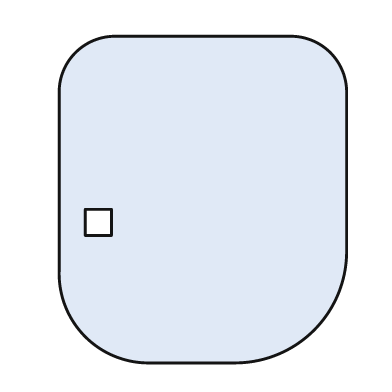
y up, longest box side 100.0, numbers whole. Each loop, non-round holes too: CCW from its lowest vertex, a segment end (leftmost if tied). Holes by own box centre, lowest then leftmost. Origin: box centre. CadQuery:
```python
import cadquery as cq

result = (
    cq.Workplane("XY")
    .moveTo(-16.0, -50.0)
    .lineTo(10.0, -50.0)
    .threePointArc((34.0, -40.0), (44.0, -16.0))
    .lineTo(44.0, 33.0)
    .threePointArc((39.0, 45.0), (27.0, 50.0))
    .lineTo(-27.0, 50.0)
    .threePointArc((-39.0, 45.0), (-44.0, 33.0))
    .lineTo(-44.0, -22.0)
    .threePointArc((-36.0, -42.0), (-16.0, -50.0))
    .close()
    .moveTo(-36.0, -11.0)
    .lineTo(-28.0, -11.0)
    .lineTo(-28.0, -3.0)
    .lineTo(-36.0, -3.0)
    .close()
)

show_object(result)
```